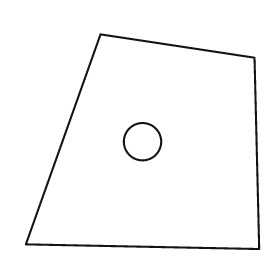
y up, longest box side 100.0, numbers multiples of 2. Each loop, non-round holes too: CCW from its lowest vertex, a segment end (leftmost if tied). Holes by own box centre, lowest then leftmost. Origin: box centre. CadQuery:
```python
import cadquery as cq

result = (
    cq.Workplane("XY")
    .moveTo(50.0, -46.0)
    .lineTo(48.0, 36.0)
    .lineTo(-18.0, 46.0)
    .lineTo(-50.0, -44.0)
    .close()
    .moveTo(0.0, 0.0)
    .circle(8.0)
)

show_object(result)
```